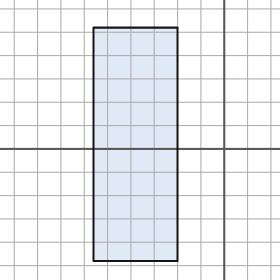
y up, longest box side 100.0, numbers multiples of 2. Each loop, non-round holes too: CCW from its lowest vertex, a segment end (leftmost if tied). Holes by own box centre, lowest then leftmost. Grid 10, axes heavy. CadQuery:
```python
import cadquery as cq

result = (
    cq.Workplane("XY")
    .moveTo(-56.0, -48.0)
    .lineTo(-20.0, -48.0)
    .lineTo(-20.0, 52.0)
    .lineTo(-56.0, 52.0)
    .close()
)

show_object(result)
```